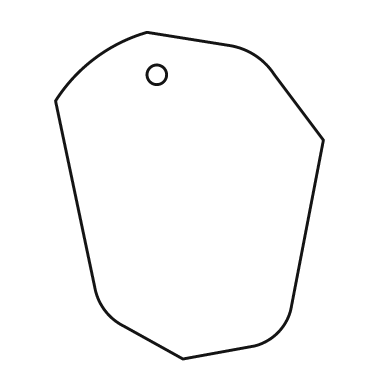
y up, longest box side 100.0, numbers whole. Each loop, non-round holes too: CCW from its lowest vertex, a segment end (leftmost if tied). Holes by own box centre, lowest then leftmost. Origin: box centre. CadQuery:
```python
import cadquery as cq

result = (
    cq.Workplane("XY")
    .moveTo(-2.0, -50.0)
    .lineTo(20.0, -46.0)
    .threePointArc((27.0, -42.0), (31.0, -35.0))
    .lineTo(41.0, 17.0)
    .lineTo(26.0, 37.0)
    .threePointArc((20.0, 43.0), (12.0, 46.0))
    .lineTo(-13.0, 50.0)
    .threePointArc((-29.0, 42.0), (-41.0, 29.0))
    .lineTo(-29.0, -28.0)
    .threePointArc((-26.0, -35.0), (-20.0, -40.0))
    .close()
    .moveTo(-10.0, 37.0)
    .circle(3.0)
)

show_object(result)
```